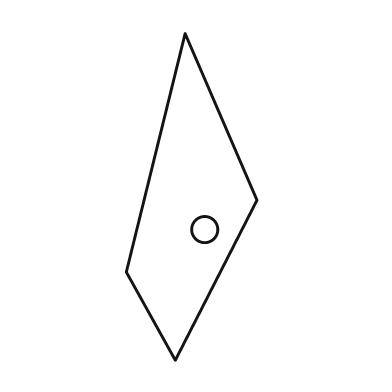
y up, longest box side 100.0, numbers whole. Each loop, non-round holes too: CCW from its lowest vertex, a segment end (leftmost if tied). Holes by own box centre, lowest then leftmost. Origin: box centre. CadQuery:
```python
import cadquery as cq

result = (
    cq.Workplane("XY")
    .moveTo(-5.0, -50.0)
    .lineTo(20.0, -1.0)
    .lineTo(-2.0, 50.0)
    .lineTo(-20.0, -23.0)
    .close()
    .moveTo(4.0, -10.0)
    .circle(4.0)
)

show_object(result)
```